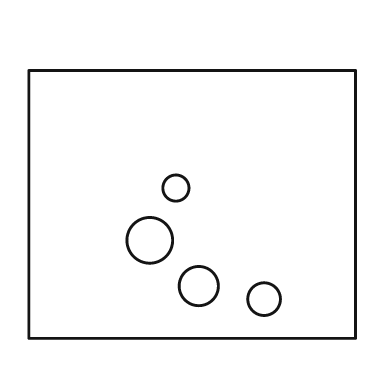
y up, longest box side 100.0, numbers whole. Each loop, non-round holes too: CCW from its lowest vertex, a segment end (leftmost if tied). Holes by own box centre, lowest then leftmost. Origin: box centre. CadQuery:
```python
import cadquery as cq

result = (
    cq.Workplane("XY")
    .moveTo(-50.0, -41.0)
    .lineTo(50.0, -41.0)
    .lineTo(50.0, 41.0)
    .lineTo(-50.0, 41.0)
    .close()
    .moveTo(22.0, -29.0)
    .circle(5.0)
    .moveTo(2.0, -25.0)
    .circle(6.0)
    .moveTo(-13.0, -11.0)
    .circle(7.0)
    .moveTo(-5.0, 5.0)
    .circle(4.0)
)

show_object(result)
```